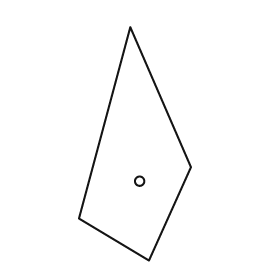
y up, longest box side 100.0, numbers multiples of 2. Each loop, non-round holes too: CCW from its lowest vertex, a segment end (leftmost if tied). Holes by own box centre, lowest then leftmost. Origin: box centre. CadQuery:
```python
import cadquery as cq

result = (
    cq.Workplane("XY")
    .moveTo(6.0, -50.0)
    .lineTo(24.0, -10.0)
    .lineTo(-2.0, 50.0)
    .lineTo(-24.0, -32.0)
    .close()
    .moveTo(2.0, -16.0)
    .circle(2.0)
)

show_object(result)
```